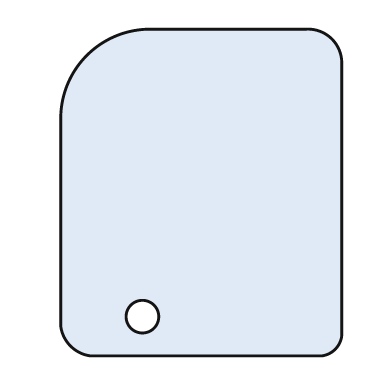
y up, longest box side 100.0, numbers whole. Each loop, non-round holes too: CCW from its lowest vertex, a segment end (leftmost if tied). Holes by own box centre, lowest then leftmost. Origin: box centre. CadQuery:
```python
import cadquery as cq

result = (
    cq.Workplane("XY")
    .moveTo(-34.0, -50.0)
    .lineTo(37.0, -50.0)
    .threePointArc((41.0, -48.0), (43.0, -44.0))
    .lineTo(43.0, 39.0)
    .threePointArc((40.0, 47.0), (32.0, 50.0))
    .lineTo(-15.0, 50.0)
    .threePointArc((-35.0, 42.0), (-43.0, 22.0))
    .lineTo(-43.0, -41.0)
    .threePointArc((-40.0, -47.0), (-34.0, -50.0))
    .close()
    .moveTo(-18.0, -38.0)
    .circle(5.0)
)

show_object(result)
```